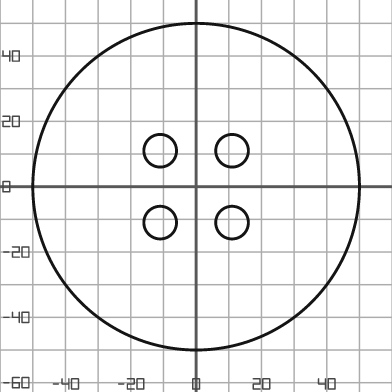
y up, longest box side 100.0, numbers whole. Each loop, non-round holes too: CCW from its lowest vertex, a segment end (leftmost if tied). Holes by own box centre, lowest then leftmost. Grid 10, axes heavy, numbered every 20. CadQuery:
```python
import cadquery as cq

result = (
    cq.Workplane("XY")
    .moveTo(0.0, 0.0)
    .circle(50.0)
    .moveTo(-11.0, -11.0)
    .circle(5.0)
    .moveTo(11.0, -11.0)
    .circle(5.0)
    .moveTo(-11.0, 11.0)
    .circle(5.0)
    .moveTo(11.0, 11.0)
    .circle(5.0)
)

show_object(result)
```